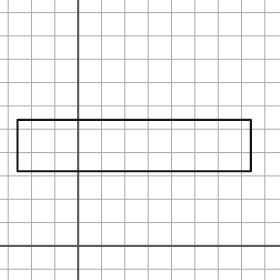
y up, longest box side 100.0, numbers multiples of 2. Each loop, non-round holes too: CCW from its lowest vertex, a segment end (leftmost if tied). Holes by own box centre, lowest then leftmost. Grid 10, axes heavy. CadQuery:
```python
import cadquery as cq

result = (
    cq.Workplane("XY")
    .moveTo(-26.0, 32.0)
    .lineTo(74.0, 32.0)
    .lineTo(74.0, 54.0)
    .lineTo(-26.0, 54.0)
    .close()
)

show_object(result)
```